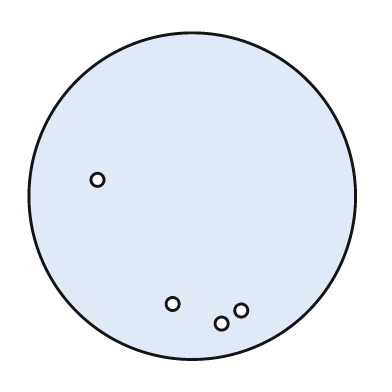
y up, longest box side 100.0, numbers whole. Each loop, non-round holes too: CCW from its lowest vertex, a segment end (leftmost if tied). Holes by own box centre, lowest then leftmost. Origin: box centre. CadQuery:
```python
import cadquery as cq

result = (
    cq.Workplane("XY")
    .moveTo(0.0, 0.0)
    .circle(50.0)
    .moveTo(9.0, -39.0)
    .circle(2.0)
    .moveTo(15.0, -35.0)
    .circle(2.0)
    .moveTo(-6.0, -33.0)
    .circle(2.0)
    .moveTo(-29.0, 5.0)
    .circle(2.0)
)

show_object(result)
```